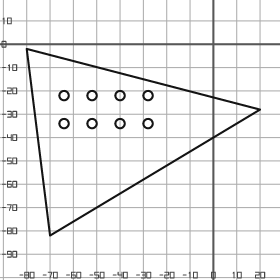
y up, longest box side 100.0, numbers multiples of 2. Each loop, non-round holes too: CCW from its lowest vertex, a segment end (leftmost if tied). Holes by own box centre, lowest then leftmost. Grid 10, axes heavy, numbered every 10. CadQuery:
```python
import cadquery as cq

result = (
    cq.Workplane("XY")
    .moveTo(-70.0, -82.0)
    .lineTo(20.0, -28.0)
    .lineTo(-80.0, -2.0)
    .close()
    .moveTo(-64.0, -34.0)
    .circle(2.0)
    .moveTo(-52.0, -34.0)
    .circle(2.0)
    .moveTo(-40.0, -34.0)
    .circle(2.0)
    .moveTo(-28.0, -34.0)
    .circle(2.0)
    .moveTo(-64.0, -22.0)
    .circle(2.0)
    .moveTo(-52.0, -22.0)
    .circle(2.0)
    .moveTo(-40.0, -22.0)
    .circle(2.0)
    .moveTo(-28.0, -22.0)
    .circle(2.0)
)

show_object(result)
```